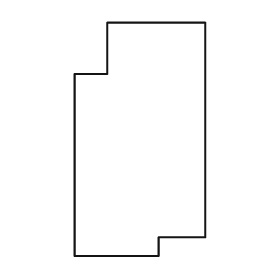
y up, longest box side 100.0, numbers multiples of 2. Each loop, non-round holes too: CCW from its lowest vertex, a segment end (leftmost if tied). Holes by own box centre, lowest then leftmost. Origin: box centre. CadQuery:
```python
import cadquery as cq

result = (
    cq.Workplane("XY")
    .moveTo(-28.0, -50.0)
    .lineTo(8.0, -50.0)
    .lineTo(8.0, -42.0)
    .lineTo(28.0, -42.0)
    .lineTo(28.0, 50.0)
    .lineTo(-14.0, 50.0)
    .lineTo(-14.0, 28.0)
    .lineTo(-28.0, 28.0)
    .close()
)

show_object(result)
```